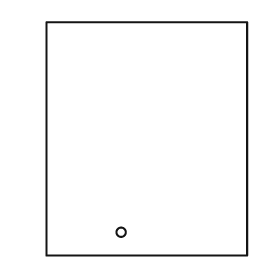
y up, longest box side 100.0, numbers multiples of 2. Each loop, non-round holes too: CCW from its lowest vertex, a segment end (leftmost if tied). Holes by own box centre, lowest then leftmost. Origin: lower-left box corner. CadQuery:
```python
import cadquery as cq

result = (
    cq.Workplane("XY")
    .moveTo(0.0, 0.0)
    .lineTo(86.0, 0.0)
    .lineTo(86.0, 100.0)
    .lineTo(0.0, 100.0)
    .close()
    .moveTo(32.0, 10.0)
    .circle(2.0)
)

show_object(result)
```